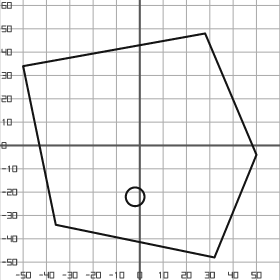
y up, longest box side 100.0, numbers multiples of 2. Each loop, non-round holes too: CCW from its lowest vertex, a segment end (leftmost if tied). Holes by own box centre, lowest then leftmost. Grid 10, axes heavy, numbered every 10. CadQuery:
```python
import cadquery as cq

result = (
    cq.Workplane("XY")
    .moveTo(32.0, -48.0)
    .lineTo(50.0, -4.0)
    .lineTo(28.0, 48.0)
    .lineTo(-50.0, 34.0)
    .lineTo(-36.0, -34.0)
    .close()
    .moveTo(-2.0, -22.0)
    .circle(4.0)
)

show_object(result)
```